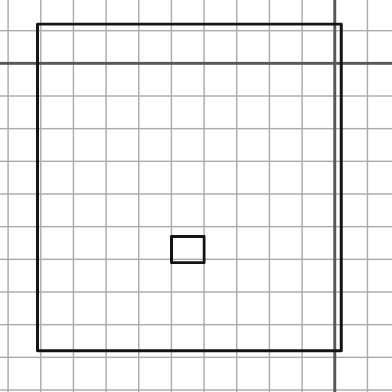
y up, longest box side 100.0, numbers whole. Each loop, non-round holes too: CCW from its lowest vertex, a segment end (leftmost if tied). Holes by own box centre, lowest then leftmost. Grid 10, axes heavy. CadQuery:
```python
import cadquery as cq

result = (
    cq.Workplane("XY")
    .moveTo(-91.0, -88.0)
    .lineTo(2.0, -88.0)
    .lineTo(2.0, 12.0)
    .lineTo(-91.0, 12.0)
    .close()
    .moveTo(-50.0, -61.0)
    .lineTo(-40.0, -61.0)
    .lineTo(-40.0, -53.0)
    .lineTo(-50.0, -53.0)
    .close()
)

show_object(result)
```